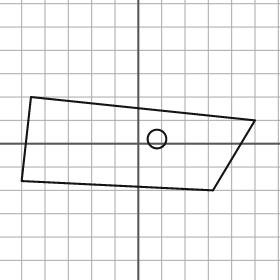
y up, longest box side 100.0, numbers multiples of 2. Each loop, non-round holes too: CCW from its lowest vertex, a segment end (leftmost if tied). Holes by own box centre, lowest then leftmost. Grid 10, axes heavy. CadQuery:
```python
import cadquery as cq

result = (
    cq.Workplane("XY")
    .moveTo(32.0, -20.0)
    .lineTo(50.0, 10.0)
    .lineTo(-46.0, 20.0)
    .lineTo(-50.0, -16.0)
    .close()
    .moveTo(8.0, 2.0)
    .circle(4.0)
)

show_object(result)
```